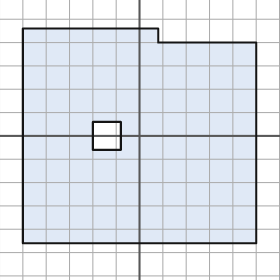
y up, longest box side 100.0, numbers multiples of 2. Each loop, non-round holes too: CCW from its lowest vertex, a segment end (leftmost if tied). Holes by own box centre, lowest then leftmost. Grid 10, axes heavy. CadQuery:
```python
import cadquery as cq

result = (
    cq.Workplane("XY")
    .moveTo(-50.0, -46.0)
    .lineTo(50.0, -46.0)
    .lineTo(50.0, 40.0)
    .lineTo(8.0, 40.0)
    .lineTo(8.0, 46.0)
    .lineTo(-50.0, 46.0)
    .close()
    .moveTo(-20.0, -6.0)
    .lineTo(-8.0, -6.0)
    .lineTo(-8.0, 6.0)
    .lineTo(-20.0, 6.0)
    .close()
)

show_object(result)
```